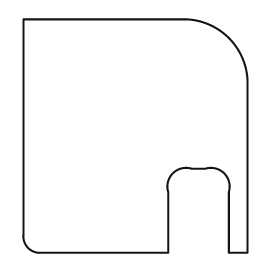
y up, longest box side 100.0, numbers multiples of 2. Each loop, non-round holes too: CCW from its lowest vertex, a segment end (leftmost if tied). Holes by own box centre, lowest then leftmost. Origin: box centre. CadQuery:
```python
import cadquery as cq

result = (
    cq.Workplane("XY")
    .moveTo(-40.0, -50.0)
    .lineTo(14.0, -50.0)
    .lineTo(14.0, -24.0)
    .threePointArc((16.0, -16.0), (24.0, -14.0))
    .lineTo(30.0, -14.0)
    .threePointArc((38.0, -16.0), (40.0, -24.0))
    .lineTo(40.0, -50.0)
    .lineTo(48.0, -50.0)
    .lineTo(48.0, 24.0)
    .threePointArc((40.0, 42.0), (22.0, 50.0))
    .lineTo(-48.0, 50.0)
    .lineTo(-48.0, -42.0)
    .threePointArc((-46.0, -48.0), (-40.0, -50.0))
    .close()
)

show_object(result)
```